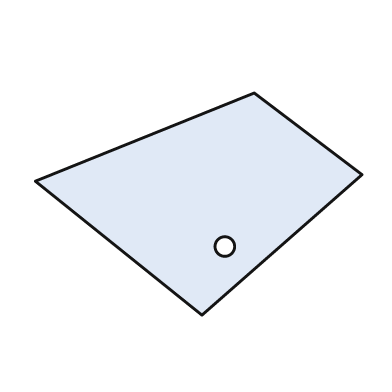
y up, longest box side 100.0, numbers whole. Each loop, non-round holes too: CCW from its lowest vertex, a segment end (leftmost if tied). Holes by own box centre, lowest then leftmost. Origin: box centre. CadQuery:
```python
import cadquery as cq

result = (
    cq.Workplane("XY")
    .moveTo(1.0, -34.0)
    .lineTo(50.0, 9.0)
    .lineTo(17.0, 34.0)
    .lineTo(-50.0, 7.0)
    .close()
    .moveTo(8.0, -13.0)
    .circle(3.0)
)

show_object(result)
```